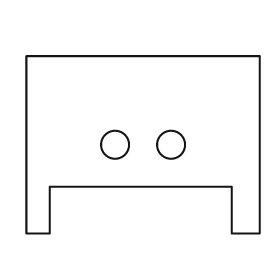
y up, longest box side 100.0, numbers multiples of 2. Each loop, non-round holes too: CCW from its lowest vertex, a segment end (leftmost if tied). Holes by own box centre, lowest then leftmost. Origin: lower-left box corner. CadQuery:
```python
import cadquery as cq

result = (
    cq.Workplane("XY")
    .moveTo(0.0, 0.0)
    .lineTo(10.0, 0.0)
    .lineTo(10.0, 20.0)
    .lineTo(88.0, 20.0)
    .lineTo(88.0, 0.0)
    .lineTo(100.0, 0.0)
    .lineTo(100.0, 76.0)
    .lineTo(0.0, 76.0)
    .close()
    .moveTo(38.0, 38.0)
    .circle(6.0)
    .moveTo(62.0, 38.0)
    .circle(6.0)
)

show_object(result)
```